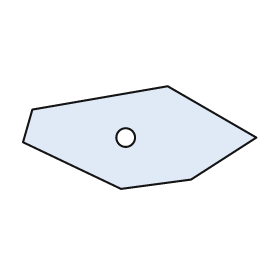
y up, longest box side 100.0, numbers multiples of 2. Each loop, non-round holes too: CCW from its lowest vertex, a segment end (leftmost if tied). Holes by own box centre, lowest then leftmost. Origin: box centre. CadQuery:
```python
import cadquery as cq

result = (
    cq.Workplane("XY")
    .moveTo(-8.0, -22.0)
    .lineTo(22.0, -18.0)
    .lineTo(50.0, 0.0)
    .lineTo(12.0, 22.0)
    .lineTo(-46.0, 12.0)
    .lineTo(-50.0, -2.0)
    .close()
    .moveTo(-6.0, 0.0)
    .circle(4.0)
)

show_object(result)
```